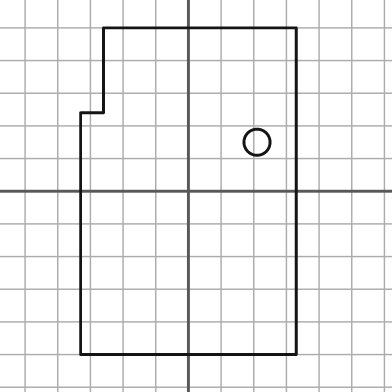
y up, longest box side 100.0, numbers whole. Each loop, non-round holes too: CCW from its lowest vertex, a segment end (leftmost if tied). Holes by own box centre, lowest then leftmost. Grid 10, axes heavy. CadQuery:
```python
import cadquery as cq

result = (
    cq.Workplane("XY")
    .moveTo(-33.0, -50.0)
    .lineTo(33.0, -50.0)
    .lineTo(33.0, 50.0)
    .lineTo(-26.0, 50.0)
    .lineTo(-26.0, 24.0)
    .lineTo(-33.0, 24.0)
    .close()
    .moveTo(21.0, 15.0)
    .circle(4.0)
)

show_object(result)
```